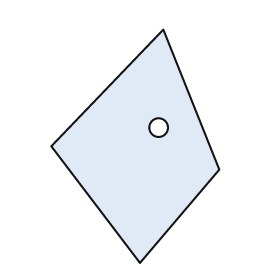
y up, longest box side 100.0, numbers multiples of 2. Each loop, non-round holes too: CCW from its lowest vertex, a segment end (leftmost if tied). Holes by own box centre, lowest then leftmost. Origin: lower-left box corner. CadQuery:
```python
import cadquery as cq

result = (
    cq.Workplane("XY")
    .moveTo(38.0, 0.0)
    .lineTo(72.0, 40.0)
    .lineTo(48.0, 100.0)
    .lineTo(0.0, 50.0)
    .close()
    .moveTo(46.0, 58.0)
    .circle(4.0)
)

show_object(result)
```